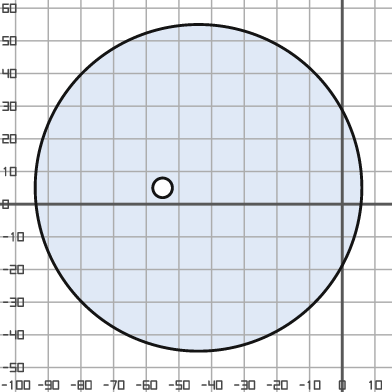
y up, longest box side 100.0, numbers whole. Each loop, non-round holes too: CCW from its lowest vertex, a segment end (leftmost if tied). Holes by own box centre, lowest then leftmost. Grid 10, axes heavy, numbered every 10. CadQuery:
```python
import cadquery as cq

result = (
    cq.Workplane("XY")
    .moveTo(-44.0, 5.0)
    .circle(50.0)
    .moveTo(-55.0, 5.0)
    .circle(3.0)
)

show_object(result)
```